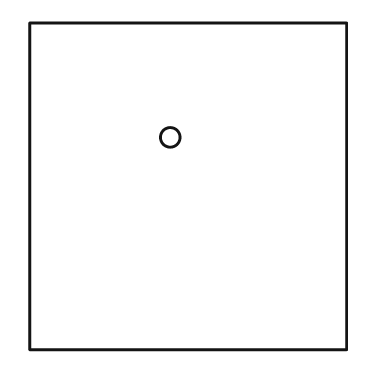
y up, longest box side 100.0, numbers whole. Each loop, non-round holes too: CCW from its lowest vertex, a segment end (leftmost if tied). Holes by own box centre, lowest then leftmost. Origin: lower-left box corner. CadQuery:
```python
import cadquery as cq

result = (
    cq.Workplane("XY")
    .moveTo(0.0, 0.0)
    .lineTo(97.0, 0.0)
    .lineTo(97.0, 100.0)
    .lineTo(0.0, 100.0)
    .close()
    .moveTo(43.0, 65.0)
    .circle(3.0)
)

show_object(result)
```